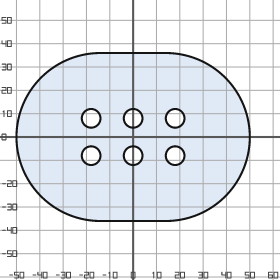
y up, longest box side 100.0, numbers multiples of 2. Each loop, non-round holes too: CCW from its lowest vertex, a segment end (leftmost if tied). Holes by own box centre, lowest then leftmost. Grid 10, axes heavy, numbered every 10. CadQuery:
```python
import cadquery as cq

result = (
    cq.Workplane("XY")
    .moveTo(-14.0, -36.0)
    .lineTo(14.0, -36.0)
    .threePointArc((50.0, 0.0), (14.0, 36.0))
    .lineTo(-14.0, 36.0)
    .threePointArc((-50.0, 0.0), (-14.0, -36.0))
    .close()
    .moveTo(-18.0, -8.0)
    .circle(4.0)
    .moveTo(0.0, -8.0)
    .circle(4.0)
    .moveTo(18.0, -8.0)
    .circle(4.0)
    .moveTo(-18.0, 8.0)
    .circle(4.0)
    .moveTo(0.0, 8.0)
    .circle(4.0)
    .moveTo(18.0, 8.0)
    .circle(4.0)
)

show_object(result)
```